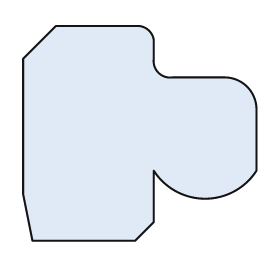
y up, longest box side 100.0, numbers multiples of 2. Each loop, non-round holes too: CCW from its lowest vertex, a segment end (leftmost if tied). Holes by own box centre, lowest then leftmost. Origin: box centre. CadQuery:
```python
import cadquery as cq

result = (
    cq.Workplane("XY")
    .moveTo(-46.0, -46.0)
    .lineTo(-2.0, -46.0)
    .lineTo(6.0, -38.0)
    .lineTo(6.0, -16.0)
    .threePointArc((28.0, -28.0), (50.0, -16.0))
    .lineTo(50.0, 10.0)
    .threePointArc((46.0, 20.0), (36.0, 24.0))
    .lineTo(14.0, 24.0)
    .threePointArc((8.0, 26.0), (6.0, 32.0))
    .lineTo(6.0, 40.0)
    .threePointArc((4.0, 44.0), (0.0, 46.0))
    .lineTo(-36.0, 46.0)
    .lineTo(-50.0, 32.0)
    .lineTo(-50.0, -26.0)
    .close()
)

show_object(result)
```